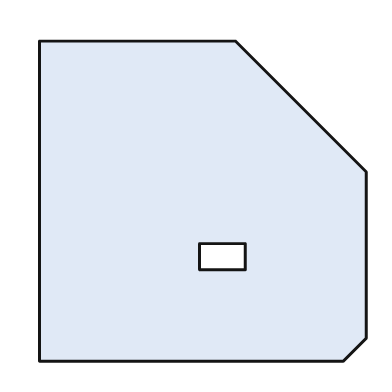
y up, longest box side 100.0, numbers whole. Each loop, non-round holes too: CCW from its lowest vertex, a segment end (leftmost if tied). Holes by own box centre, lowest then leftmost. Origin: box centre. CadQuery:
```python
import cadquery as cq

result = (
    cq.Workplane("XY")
    .moveTo(-50.0, -49.0)
    .lineTo(43.0, -49.0)
    .lineTo(50.0, -42.0)
    .lineTo(50.0, 9.0)
    .lineTo(10.0, 49.0)
    .lineTo(-50.0, 49.0)
    .close()
    .moveTo(-1.0, -21.0)
    .lineTo(13.0, -21.0)
    .lineTo(13.0, -13.0)
    .lineTo(-1.0, -13.0)
    .close()
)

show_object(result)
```